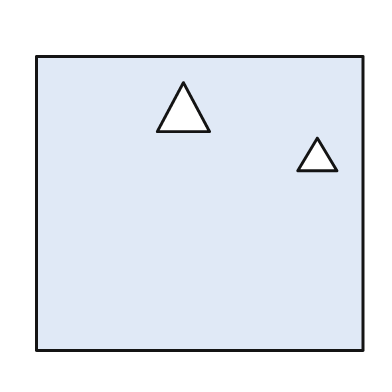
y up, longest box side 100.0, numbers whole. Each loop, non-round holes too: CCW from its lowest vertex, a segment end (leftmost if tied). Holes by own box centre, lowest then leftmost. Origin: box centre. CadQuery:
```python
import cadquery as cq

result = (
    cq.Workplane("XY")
    .moveTo(-50.0, -45.0)
    .lineTo(50.0, -45.0)
    .lineTo(50.0, 45.0)
    .lineTo(-50.0, 45.0)
    .close()
    .moveTo(30.0, 10.0)
    .lineTo(42.0, 10.0)
    .lineTo(36.0, 20.0)
    .close()
    .moveTo(-13.0, 22.0)
    .lineTo(3.0, 22.0)
    .lineTo(-5.0, 37.0)
    .close()
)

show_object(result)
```